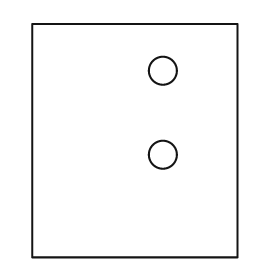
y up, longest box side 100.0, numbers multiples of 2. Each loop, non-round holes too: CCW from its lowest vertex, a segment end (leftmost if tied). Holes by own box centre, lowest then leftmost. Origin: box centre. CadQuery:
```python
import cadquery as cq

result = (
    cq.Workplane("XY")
    .moveTo(-44.0, -50.0)
    .lineTo(44.0, -50.0)
    .lineTo(44.0, 50.0)
    .lineTo(-44.0, 50.0)
    .close()
    .moveTo(12.0, -6.0)
    .circle(6.0)
    .moveTo(12.0, 30.0)
    .circle(6.0)
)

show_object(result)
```